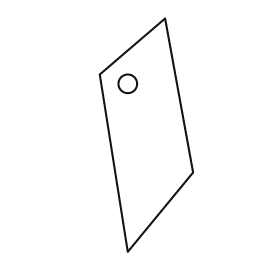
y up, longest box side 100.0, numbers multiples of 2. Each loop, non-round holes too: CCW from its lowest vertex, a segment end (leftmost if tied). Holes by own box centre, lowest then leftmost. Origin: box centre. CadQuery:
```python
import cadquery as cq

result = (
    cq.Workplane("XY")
    .moveTo(-8.0, -50.0)
    .lineTo(20.0, -16.0)
    .lineTo(8.0, 50.0)
    .lineTo(-20.0, 26.0)
    .close()
    .moveTo(-8.0, 22.0)
    .circle(4.0)
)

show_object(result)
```